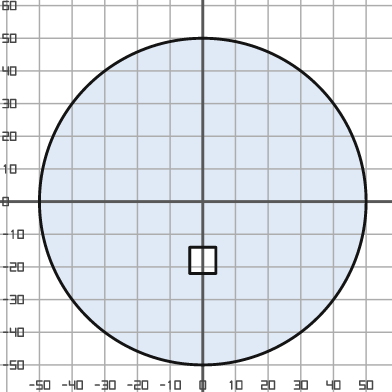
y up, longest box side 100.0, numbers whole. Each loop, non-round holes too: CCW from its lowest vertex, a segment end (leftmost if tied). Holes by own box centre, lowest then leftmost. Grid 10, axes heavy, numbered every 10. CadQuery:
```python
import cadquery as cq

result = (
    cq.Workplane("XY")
    .moveTo(0.0, 0.0)
    .circle(50.0)
    .moveTo(-4.0, -22.0)
    .lineTo(4.0, -22.0)
    .lineTo(4.0, -14.0)
    .lineTo(-4.0, -14.0)
    .close()
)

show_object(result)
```